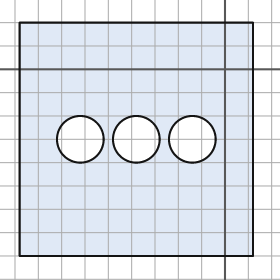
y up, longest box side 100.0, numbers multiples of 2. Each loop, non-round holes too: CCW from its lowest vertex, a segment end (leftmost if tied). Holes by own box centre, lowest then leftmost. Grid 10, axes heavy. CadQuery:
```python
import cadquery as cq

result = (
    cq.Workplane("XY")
    .moveTo(-88.0, -80.0)
    .lineTo(12.0, -80.0)
    .lineTo(12.0, 20.0)
    .lineTo(-88.0, 20.0)
    .close()
    .moveTo(-62.0, -30.0)
    .circle(10.0)
    .moveTo(-38.0, -30.0)
    .circle(10.0)
    .moveTo(-14.0, -30.0)
    .circle(10.0)
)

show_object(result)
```